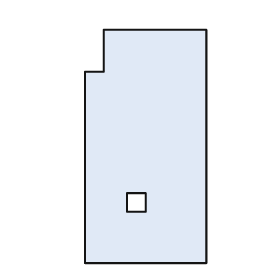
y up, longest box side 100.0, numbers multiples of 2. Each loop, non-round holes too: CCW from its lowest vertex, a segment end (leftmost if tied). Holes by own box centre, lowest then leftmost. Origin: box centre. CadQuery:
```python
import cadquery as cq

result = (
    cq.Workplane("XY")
    .moveTo(-26.0, -50.0)
    .lineTo(26.0, -50.0)
    .lineTo(26.0, 50.0)
    .lineTo(-18.0, 50.0)
    .lineTo(-18.0, 32.0)
    .lineTo(-26.0, 32.0)
    .close()
    .moveTo(-8.0, -28.0)
    .lineTo(0.0, -28.0)
    .lineTo(0.0, -20.0)
    .lineTo(-8.0, -20.0)
    .close()
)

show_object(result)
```